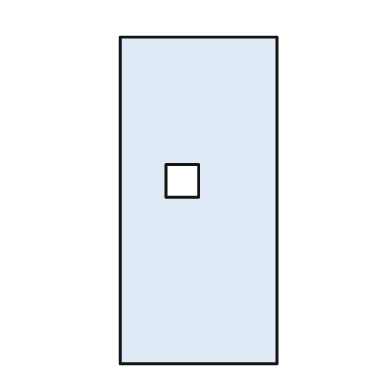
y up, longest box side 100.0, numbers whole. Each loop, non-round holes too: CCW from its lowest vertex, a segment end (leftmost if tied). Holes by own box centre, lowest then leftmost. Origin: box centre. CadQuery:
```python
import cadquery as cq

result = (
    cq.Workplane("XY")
    .moveTo(-24.0, -50.0)
    .lineTo(24.0, -50.0)
    .lineTo(24.0, 50.0)
    .lineTo(-24.0, 50.0)
    .close()
    .moveTo(-10.0, 1.0)
    .lineTo(0.0, 1.0)
    .lineTo(0.0, 11.0)
    .lineTo(-10.0, 11.0)
    .close()
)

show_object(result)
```